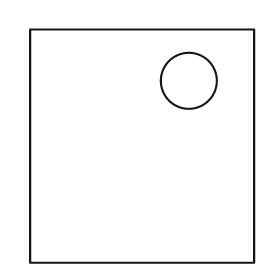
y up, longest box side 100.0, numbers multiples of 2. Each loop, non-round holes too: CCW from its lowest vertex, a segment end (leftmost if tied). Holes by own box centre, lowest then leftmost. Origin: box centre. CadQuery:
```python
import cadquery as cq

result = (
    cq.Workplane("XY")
    .moveTo(-48.0, -50.0)
    .lineTo(48.0, -50.0)
    .lineTo(48.0, 50.0)
    .lineTo(-48.0, 50.0)
    .close()
    .moveTo(20.0, 28.0)
    .circle(12.0)
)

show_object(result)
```